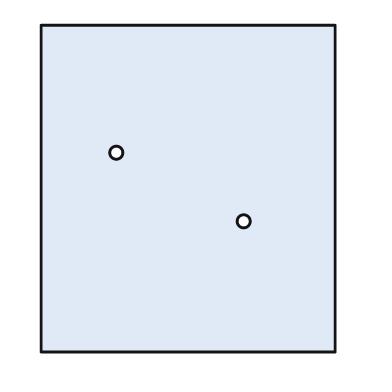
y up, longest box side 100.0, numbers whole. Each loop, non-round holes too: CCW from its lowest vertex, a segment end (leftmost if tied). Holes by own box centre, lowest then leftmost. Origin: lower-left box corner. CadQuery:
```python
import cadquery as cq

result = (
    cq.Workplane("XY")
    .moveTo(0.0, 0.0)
    .lineTo(90.0, 0.0)
    .lineTo(90.0, 100.0)
    .lineTo(0.0, 100.0)
    .close()
    .moveTo(62.0, 40.0)
    .circle(2.0)
    .moveTo(23.0, 61.0)
    .circle(2.0)
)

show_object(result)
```